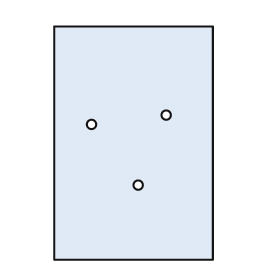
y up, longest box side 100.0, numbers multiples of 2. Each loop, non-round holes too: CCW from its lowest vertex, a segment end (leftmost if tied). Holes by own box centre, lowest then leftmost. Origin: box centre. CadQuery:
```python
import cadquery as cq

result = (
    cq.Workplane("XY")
    .moveTo(-34.0, -50.0)
    .lineTo(34.0, -50.0)
    .lineTo(34.0, 50.0)
    .lineTo(-34.0, 50.0)
    .close()
    .moveTo(2.0, -18.0)
    .circle(2.0)
    .moveTo(-18.0, 8.0)
    .circle(2.0)
    .moveTo(14.0, 12.0)
    .circle(2.0)
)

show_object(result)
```